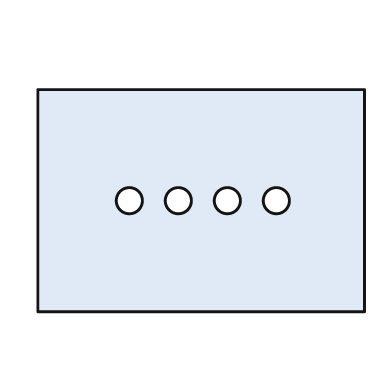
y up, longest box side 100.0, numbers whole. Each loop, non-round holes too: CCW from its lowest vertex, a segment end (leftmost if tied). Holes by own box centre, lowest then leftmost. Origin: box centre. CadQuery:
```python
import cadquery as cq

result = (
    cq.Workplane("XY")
    .moveTo(-50.0, -34.0)
    .lineTo(50.0, -34.0)
    .lineTo(50.0, 34.0)
    .lineTo(-50.0, 34.0)
    .close()
    .moveTo(-22.0, 0.0)
    .circle(4.0)
    .moveTo(-7.0, 0.0)
    .circle(4.0)
    .moveTo(8.0, 0.0)
    .circle(4.0)
    .moveTo(23.0, 0.0)
    .circle(4.0)
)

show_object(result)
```